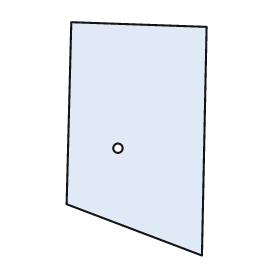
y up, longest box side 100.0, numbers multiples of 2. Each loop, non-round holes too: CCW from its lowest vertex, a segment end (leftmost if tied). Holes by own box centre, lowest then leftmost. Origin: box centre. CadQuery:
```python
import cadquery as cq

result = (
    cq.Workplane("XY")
    .moveTo(28.0, -50.0)
    .lineTo(30.0, 48.0)
    .lineTo(-28.0, 50.0)
    .lineTo(-30.0, -28.0)
    .close()
    .moveTo(-8.0, -4.0)
    .circle(2.0)
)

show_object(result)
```